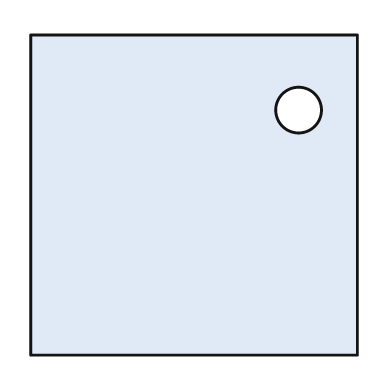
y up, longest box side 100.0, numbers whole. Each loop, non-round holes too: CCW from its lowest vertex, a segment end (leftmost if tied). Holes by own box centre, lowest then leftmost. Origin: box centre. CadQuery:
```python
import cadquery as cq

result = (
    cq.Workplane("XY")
    .moveTo(-50.0, -49.0)
    .lineTo(50.0, -49.0)
    .lineTo(50.0, 49.0)
    .lineTo(-50.0, 49.0)
    .close()
    .moveTo(32.0, 26.0)
    .circle(7.0)
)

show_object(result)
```